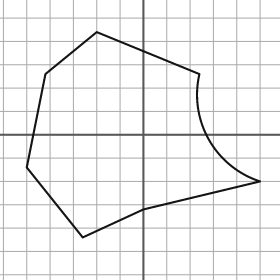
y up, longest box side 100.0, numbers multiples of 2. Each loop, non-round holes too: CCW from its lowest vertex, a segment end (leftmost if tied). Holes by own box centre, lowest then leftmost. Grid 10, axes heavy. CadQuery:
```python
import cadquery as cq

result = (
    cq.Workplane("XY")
    .moveTo(-26.0, -44.0)
    .lineTo(0.0, -32.0)
    .lineTo(50.0, -20.0)
    .threePointArc((28.0, -2.0), (24.0, 26.0))
    .lineTo(-20.0, 44.0)
    .lineTo(-42.0, 26.0)
    .lineTo(-50.0, -14.0)
    .close()
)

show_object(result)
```